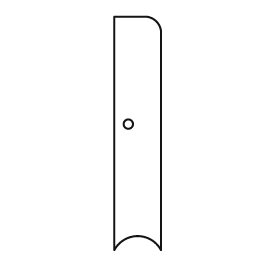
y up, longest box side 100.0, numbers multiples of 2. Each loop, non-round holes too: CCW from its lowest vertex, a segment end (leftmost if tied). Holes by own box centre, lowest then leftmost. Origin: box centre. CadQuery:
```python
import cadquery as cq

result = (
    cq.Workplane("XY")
    .moveTo(-10.0, -50.0)
    .threePointArc((0.0, -44.0), (10.0, -50.0))
    .lineTo(10.0, 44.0)
    .threePointArc((8.0, 48.0), (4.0, 50.0))
    .lineTo(-10.0, 50.0)
    .close()
    .moveTo(-4.0, 4.0)
    .circle(2.0)
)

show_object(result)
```